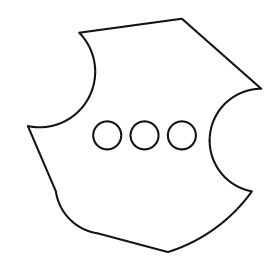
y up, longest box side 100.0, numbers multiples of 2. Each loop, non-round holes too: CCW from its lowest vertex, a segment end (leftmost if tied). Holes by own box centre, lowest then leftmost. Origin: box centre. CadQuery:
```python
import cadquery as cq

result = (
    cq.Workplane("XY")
    .moveTo(10.0, -50.0)
    .threePointArc((30.0, -40.0), (46.0, -24.0))
    .threePointArc((28.0, 0.0), (50.0, 20.0))
    .lineTo(16.0, 50.0)
    .lineTo(-28.0, 44.0)
    .threePointArc((-24.0, 16.0), (-50.0, 4.0))
    .lineTo(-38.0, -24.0)
    .threePointArc((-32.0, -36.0), (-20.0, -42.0))
    .close()
    .moveTo(-16.0, 0.0)
    .circle(6.0)
    .moveTo(0.0, 0.0)
    .circle(6.0)
    .moveTo(16.0, 0.0)
    .circle(6.0)
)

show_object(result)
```